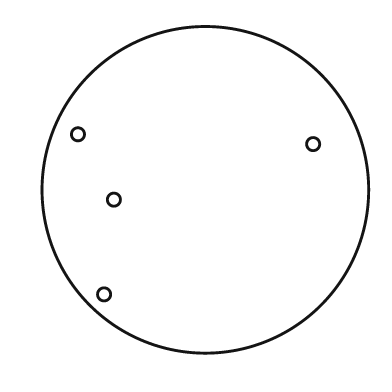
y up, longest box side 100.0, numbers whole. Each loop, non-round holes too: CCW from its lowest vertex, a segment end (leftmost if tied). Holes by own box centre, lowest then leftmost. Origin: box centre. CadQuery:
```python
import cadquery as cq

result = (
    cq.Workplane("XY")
    .moveTo(0.0, 0.0)
    .circle(50.0)
    .moveTo(-31.0, -32.0)
    .circle(2.0)
    .moveTo(-28.0, -3.0)
    .circle(2.0)
    .moveTo(33.0, 14.0)
    .circle(2.0)
    .moveTo(-39.0, 17.0)
    .circle(2.0)
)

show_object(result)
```